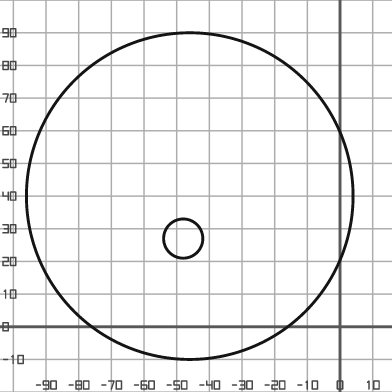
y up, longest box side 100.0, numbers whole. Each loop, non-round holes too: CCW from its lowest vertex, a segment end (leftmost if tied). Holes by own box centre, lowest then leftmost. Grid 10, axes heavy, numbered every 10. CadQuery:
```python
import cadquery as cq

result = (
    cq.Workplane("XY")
    .moveTo(-46.0, 40.0)
    .circle(50.0)
    .moveTo(-48.0, 27.0)
    .circle(6.0)
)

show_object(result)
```